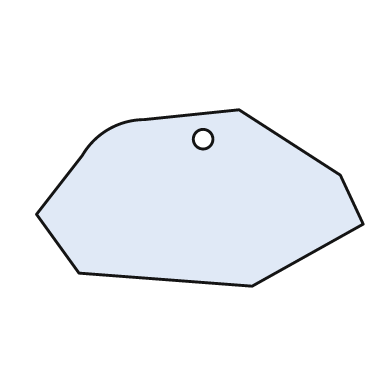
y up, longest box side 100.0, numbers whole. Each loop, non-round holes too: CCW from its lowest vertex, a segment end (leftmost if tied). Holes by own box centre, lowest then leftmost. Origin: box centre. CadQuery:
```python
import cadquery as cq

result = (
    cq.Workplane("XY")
    .moveTo(16.0, -27.0)
    .lineTo(50.0, -8.0)
    .lineTo(43.0, 7.0)
    .lineTo(12.0, 27.0)
    .lineTo(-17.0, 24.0)
    .threePointArc((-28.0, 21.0), (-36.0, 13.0))
    .lineTo(-50.0, -5.0)
    .lineTo(-37.0, -23.0)
    .close()
    .moveTo(1.0, 18.0)
    .circle(3.0)
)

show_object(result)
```